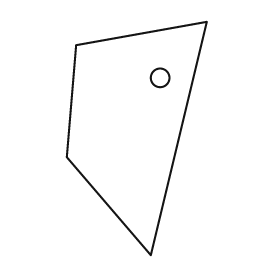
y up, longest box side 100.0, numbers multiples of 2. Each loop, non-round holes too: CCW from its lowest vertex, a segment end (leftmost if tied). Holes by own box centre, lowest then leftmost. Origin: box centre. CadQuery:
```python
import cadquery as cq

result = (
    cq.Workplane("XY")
    .moveTo(6.0, -50.0)
    .lineTo(30.0, 50.0)
    .lineTo(-26.0, 40.0)
    .lineTo(-30.0, -8.0)
    .close()
    .moveTo(10.0, 26.0)
    .circle(4.0)
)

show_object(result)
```